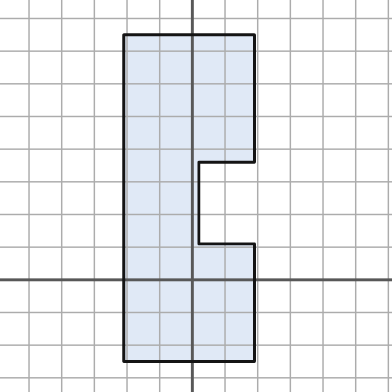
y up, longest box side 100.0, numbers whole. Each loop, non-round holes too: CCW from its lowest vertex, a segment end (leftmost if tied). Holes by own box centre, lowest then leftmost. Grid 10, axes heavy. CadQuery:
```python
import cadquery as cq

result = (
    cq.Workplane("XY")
    .moveTo(-21.0, -25.0)
    .lineTo(19.0, -25.0)
    .lineTo(19.0, 11.0)
    .lineTo(2.0, 11.0)
    .lineTo(2.0, 36.0)
    .lineTo(19.0, 36.0)
    .lineTo(19.0, 75.0)
    .lineTo(-21.0, 75.0)
    .close()
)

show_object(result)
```